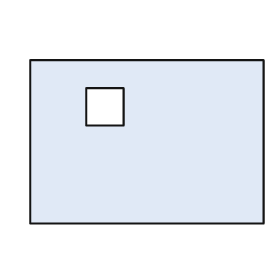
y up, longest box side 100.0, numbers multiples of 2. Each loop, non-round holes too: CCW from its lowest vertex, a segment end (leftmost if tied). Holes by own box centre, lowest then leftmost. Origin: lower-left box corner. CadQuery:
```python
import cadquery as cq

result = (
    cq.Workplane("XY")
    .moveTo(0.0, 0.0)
    .lineTo(100.0, 0.0)
    .lineTo(100.0, 70.0)
    .lineTo(0.0, 70.0)
    .close()
    .moveTo(24.0, 42.0)
    .lineTo(40.0, 42.0)
    .lineTo(40.0, 58.0)
    .lineTo(24.0, 58.0)
    .close()
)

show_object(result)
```